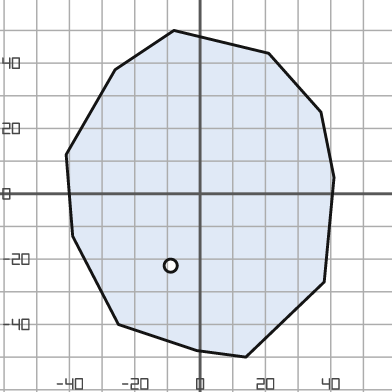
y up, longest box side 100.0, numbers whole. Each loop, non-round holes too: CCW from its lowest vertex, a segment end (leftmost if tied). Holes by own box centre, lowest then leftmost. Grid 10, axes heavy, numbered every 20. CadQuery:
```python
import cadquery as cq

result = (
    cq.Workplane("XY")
    .moveTo(14.0, -50.0)
    .lineTo(38.0, -27.0)
    .lineTo(41.0, 5.0)
    .lineTo(37.0, 25.0)
    .lineTo(21.0, 43.0)
    .lineTo(-8.0, 50.0)
    .lineTo(-26.0, 38.0)
    .lineTo(-41.0, 12.0)
    .lineTo(-39.0, -13.0)
    .lineTo(-25.0, -40.0)
    .lineTo(-1.0, -48.0)
    .close()
    .moveTo(-9.0, -22.0)
    .circle(2.0)
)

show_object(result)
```